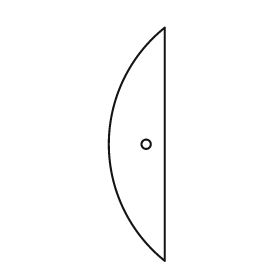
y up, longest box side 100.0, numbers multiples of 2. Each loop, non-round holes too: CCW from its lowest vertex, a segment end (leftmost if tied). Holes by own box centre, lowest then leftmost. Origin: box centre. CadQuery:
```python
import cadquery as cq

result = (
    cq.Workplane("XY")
    .moveTo(12.0, -50.0)
    .lineTo(12.0, 50.0)
    .threePointArc((-12.0, 0.0), (12.0, -50.0))
    .close()
    .moveTo(4.0, 0.0)
    .circle(2.0)
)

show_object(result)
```